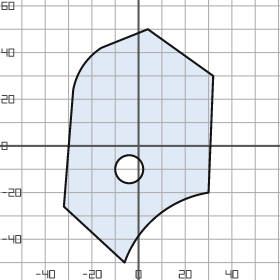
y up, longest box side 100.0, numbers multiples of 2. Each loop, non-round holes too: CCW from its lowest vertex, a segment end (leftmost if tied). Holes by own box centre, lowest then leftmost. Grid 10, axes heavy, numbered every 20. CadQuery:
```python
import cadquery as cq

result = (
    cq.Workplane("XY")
    .moveTo(-6.0, -50.0)
    .threePointArc((8.0, -30.0), (30.0, -20.0))
    .lineTo(32.0, 30.0)
    .lineTo(4.0, 50.0)
    .lineTo(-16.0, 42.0)
    .threePointArc((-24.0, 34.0), (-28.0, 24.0))
    .lineTo(-32.0, -26.0)
    .close()
    .moveTo(-4.0, -10.0)
    .circle(6.0)
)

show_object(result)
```